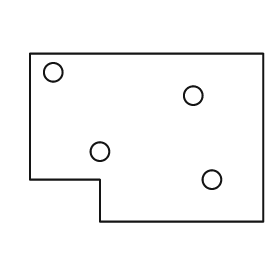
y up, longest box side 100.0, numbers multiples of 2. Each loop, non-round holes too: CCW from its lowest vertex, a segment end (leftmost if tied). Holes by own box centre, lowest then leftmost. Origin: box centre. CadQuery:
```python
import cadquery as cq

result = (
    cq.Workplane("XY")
    .moveTo(-20.0, -36.0)
    .lineTo(50.0, -36.0)
    .lineTo(50.0, 36.0)
    .lineTo(-50.0, 36.0)
    .lineTo(-50.0, -18.0)
    .lineTo(-20.0, -18.0)
    .close()
    .moveTo(28.0, -18.0)
    .circle(4.0)
    .moveTo(-20.0, -6.0)
    .circle(4.0)
    .moveTo(20.0, 18.0)
    .circle(4.0)
    .moveTo(-40.0, 28.0)
    .circle(4.0)
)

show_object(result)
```